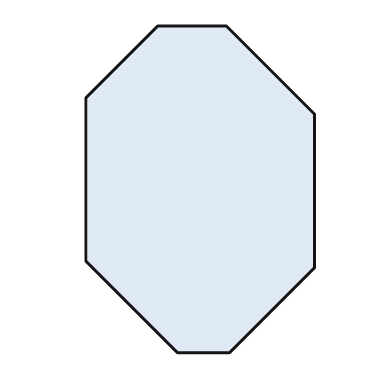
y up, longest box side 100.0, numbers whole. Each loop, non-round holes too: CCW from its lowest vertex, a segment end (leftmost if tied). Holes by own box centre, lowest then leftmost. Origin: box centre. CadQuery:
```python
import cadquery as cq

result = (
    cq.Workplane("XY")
    .moveTo(-7.0, -50.0)
    .lineTo(9.0, -50.0)
    .lineTo(35.0, -24.0)
    .lineTo(35.0, 23.0)
    .lineTo(8.0, 50.0)
    .lineTo(-13.0, 50.0)
    .lineTo(-35.0, 28.0)
    .lineTo(-35.0, -22.0)
    .close()
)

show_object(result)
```